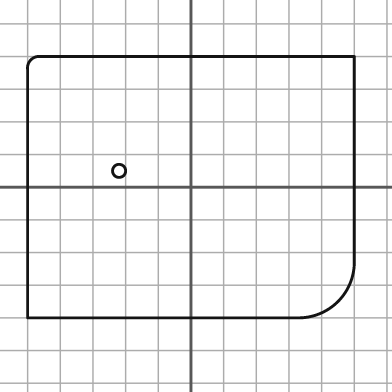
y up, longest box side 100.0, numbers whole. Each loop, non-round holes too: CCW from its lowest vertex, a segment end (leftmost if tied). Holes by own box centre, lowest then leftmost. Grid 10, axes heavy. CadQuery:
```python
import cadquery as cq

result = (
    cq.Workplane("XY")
    .moveTo(-50.0, -40.0)
    .lineTo(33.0, -40.0)
    .threePointArc((45.0, -35.0), (50.0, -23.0))
    .lineTo(50.0, 40.0)
    .lineTo(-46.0, 40.0)
    .threePointArc((-49.0, 39.0), (-50.0, 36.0))
    .close()
    .moveTo(-22.0, 5.0)
    .circle(2.0)
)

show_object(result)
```